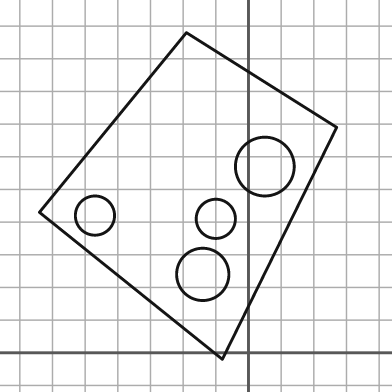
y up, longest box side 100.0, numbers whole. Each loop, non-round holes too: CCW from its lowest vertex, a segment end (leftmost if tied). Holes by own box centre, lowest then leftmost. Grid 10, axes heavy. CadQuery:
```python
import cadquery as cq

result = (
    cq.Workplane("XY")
    .moveTo(-8.0, -2.0)
    .lineTo(27.0, 69.0)
    .lineTo(-19.0, 98.0)
    .lineTo(-64.0, 43.0)
    .close()
    .moveTo(-14.0, 24.0)
    .circle(8.0)
    .moveTo(-10.0, 41.0)
    .circle(6.0)
    .moveTo(-47.0, 42.0)
    .circle(6.0)
    .moveTo(5.0, 57.0)
    .circle(9.0)
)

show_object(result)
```